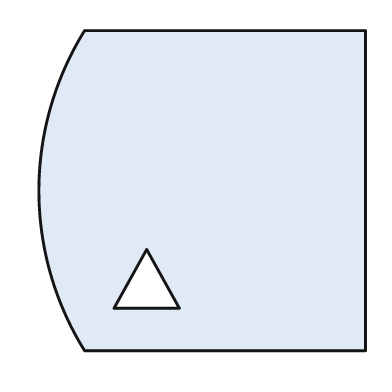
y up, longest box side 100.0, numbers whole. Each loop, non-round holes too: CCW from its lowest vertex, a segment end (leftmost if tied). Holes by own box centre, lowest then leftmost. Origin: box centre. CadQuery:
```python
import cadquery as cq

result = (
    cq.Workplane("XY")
    .moveTo(-36.0, -49.0)
    .lineTo(50.0, -49.0)
    .lineTo(50.0, 49.0)
    .lineTo(-36.0, 49.0)
    .threePointArc((-50.0, 0.0), (-36.0, -49.0))
    .close()
    .moveTo(-27.0, -36.0)
    .lineTo(-7.0, -36.0)
    .lineTo(-17.0, -18.0)
    .close()
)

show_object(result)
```